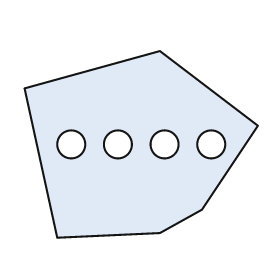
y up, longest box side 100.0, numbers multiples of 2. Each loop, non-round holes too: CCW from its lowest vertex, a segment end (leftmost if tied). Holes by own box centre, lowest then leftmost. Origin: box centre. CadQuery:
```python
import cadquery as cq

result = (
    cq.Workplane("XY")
    .moveTo(-36.0, -40.0)
    .lineTo(8.0, -38.0)
    .lineTo(26.0, -28.0)
    .lineTo(50.0, 8.0)
    .lineTo(8.0, 40.0)
    .lineTo(-50.0, 24.0)
    .close()
    .moveTo(-30.0, 0.0)
    .circle(6.0)
    .moveTo(-10.0, 0.0)
    .circle(6.0)
    .moveTo(10.0, 0.0)
    .circle(6.0)
    .moveTo(30.0, 0.0)
    .circle(6.0)
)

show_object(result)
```